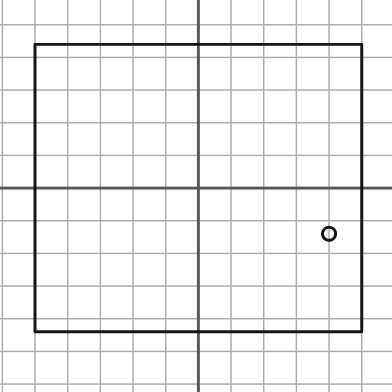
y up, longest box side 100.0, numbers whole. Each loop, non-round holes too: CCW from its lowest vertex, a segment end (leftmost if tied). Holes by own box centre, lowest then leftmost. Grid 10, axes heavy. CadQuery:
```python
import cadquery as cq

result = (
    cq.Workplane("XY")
    .moveTo(-50.0, -44.0)
    .lineTo(50.0, -44.0)
    .lineTo(50.0, 44.0)
    .lineTo(-50.0, 44.0)
    .close()
    .moveTo(40.0, -14.0)
    .circle(2.0)
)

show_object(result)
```